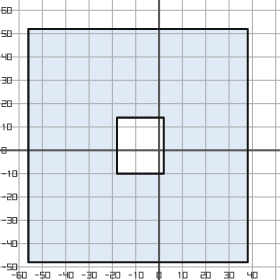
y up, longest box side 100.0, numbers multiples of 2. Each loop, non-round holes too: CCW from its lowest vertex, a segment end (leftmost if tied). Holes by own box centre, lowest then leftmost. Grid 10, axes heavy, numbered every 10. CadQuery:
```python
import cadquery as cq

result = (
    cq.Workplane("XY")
    .moveTo(-56.0, -48.0)
    .lineTo(38.0, -48.0)
    .lineTo(38.0, 52.0)
    .lineTo(-56.0, 52.0)
    .close()
    .moveTo(-18.0, -10.0)
    .lineTo(2.0, -10.0)
    .lineTo(2.0, 14.0)
    .lineTo(-18.0, 14.0)
    .close()
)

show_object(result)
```